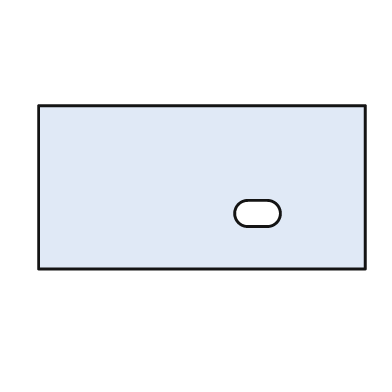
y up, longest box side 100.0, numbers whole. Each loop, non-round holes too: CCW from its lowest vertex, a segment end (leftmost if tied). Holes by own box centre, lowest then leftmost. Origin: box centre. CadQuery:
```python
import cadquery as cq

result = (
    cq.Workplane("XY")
    .moveTo(-50.0, -25.0)
    .lineTo(50.0, -25.0)
    .lineTo(50.0, 25.0)
    .lineTo(-50.0, 25.0)
    .close()
    .moveTo(14.0, -12.0)
    .lineTo(20.0, -12.0)
    .threePointArc((24.0, -8.0), (20.0, -4.0))
    .lineTo(14.0, -4.0)
    .threePointArc((10.0, -8.0), (14.0, -12.0))
    .close()
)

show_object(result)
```